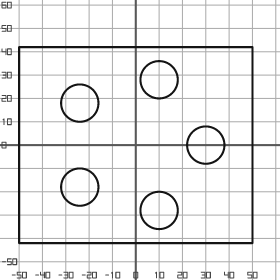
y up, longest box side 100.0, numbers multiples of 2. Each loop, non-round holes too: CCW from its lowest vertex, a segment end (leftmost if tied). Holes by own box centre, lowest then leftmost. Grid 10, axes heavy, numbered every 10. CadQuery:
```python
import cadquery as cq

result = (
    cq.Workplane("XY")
    .moveTo(-50.0, -42.0)
    .lineTo(50.0, -42.0)
    .lineTo(50.0, 42.0)
    .lineTo(-50.0, 42.0)
    .close()
    .moveTo(10.0, -28.0)
    .circle(8.0)
    .moveTo(-24.0, -18.0)
    .circle(8.0)
    .moveTo(30.0, 0.0)
    .circle(8.0)
    .moveTo(-24.0, 18.0)
    .circle(8.0)
    .moveTo(10.0, 28.0)
    .circle(8.0)
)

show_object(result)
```